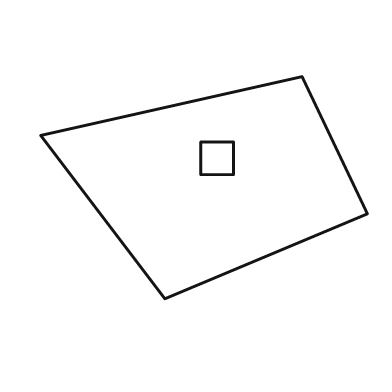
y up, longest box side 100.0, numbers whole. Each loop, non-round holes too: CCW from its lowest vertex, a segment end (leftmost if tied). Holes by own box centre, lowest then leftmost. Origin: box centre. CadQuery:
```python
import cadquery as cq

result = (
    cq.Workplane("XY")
    .moveTo(-12.0, -34.0)
    .lineTo(50.0, -8.0)
    .lineTo(30.0, 34.0)
    .lineTo(-50.0, 16.0)
    .close()
    .moveTo(-1.0, 4.0)
    .lineTo(9.0, 4.0)
    .lineTo(9.0, 14.0)
    .lineTo(-1.0, 14.0)
    .close()
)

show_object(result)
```